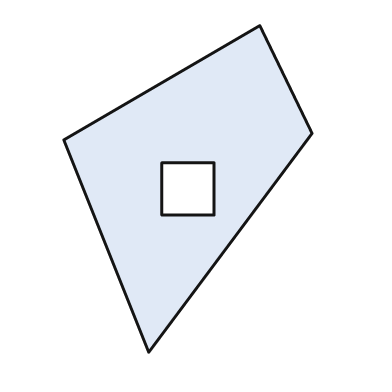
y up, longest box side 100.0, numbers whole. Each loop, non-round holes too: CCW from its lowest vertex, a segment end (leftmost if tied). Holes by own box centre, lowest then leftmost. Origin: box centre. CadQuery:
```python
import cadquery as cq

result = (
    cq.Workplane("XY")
    .moveTo(-12.0, -50.0)
    .lineTo(38.0, 17.0)
    .lineTo(22.0, 50.0)
    .lineTo(-38.0, 15.0)
    .close()
    .moveTo(-8.0, -8.0)
    .lineTo(8.0, -8.0)
    .lineTo(8.0, 8.0)
    .lineTo(-8.0, 8.0)
    .close()
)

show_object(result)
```